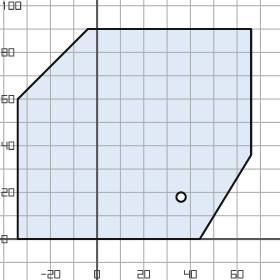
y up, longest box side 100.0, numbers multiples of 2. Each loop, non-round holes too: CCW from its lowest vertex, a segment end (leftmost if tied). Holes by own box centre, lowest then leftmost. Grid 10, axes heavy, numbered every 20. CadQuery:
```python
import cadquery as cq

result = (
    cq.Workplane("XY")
    .moveTo(-34.0, 0.0)
    .lineTo(44.0, 0.0)
    .lineTo(66.0, 36.0)
    .lineTo(66.0, 90.0)
    .lineTo(-4.0, 90.0)
    .lineTo(-34.0, 60.0)
    .close()
    .moveTo(36.0, 18.0)
    .circle(2.0)
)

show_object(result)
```